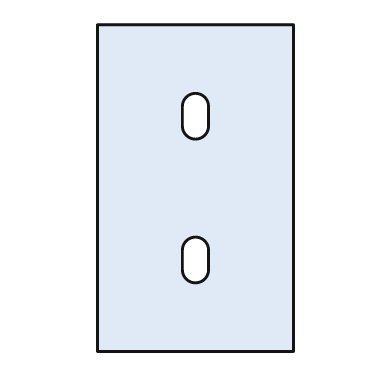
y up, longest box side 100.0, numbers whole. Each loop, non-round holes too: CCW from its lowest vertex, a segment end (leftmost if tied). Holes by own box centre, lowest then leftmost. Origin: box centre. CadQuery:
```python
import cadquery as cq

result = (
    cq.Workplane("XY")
    .moveTo(-30.0, -50.0)
    .lineTo(30.0, -50.0)
    .lineTo(30.0, 50.0)
    .lineTo(-30.0, 50.0)
    .close()
    .moveTo(-4.0, -25.0)
    .threePointArc((0.0, -29.0), (4.0, -25.0))
    .lineTo(4.0, -19.0)
    .threePointArc((0.0, -15.0), (-4.0, -19.0))
    .close()
    .moveTo(-4.0, 19.0)
    .threePointArc((0.0, 15.0), (4.0, 19.0))
    .lineTo(4.0, 25.0)
    .threePointArc((0.0, 29.0), (-4.0, 25.0))
    .close()
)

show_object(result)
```